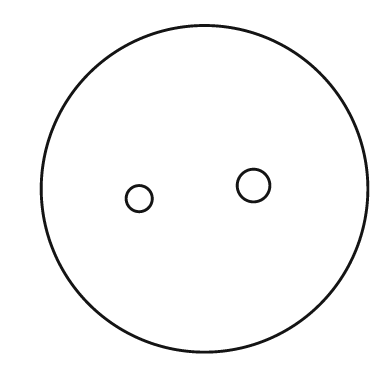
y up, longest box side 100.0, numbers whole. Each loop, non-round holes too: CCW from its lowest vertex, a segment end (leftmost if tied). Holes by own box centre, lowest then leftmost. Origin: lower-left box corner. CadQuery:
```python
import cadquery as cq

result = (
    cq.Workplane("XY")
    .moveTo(50.0, 50.0)
    .circle(50.0)
    .moveTo(30.0, 47.0)
    .circle(4.0)
    .moveTo(65.0, 51.0)
    .circle(5.0)
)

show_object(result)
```